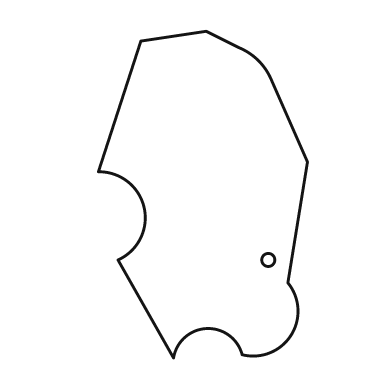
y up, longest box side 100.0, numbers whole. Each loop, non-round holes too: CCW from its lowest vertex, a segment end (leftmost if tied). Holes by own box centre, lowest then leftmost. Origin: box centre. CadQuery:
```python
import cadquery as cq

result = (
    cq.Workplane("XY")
    .moveTo(-9.0, -50.0)
    .threePointArc((1.0, -41.0), (12.0, -49.0))
    .threePointArc((27.0, -43.0), (26.0, -27.0))
    .lineTo(32.0, 10.0)
    .lineTo(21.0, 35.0)
    .threePointArc((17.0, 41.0), (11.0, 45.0))
    .lineTo(1.0, 50.0)
    .lineTo(-19.0, 47.0)
    .lineTo(-32.0, 7.0)
    .threePointArc((-18.0, -4.0), (-26.0, -20.0))
    .close()
    .moveTo(20.0, -20.0)
    .circle(2.0)
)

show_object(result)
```